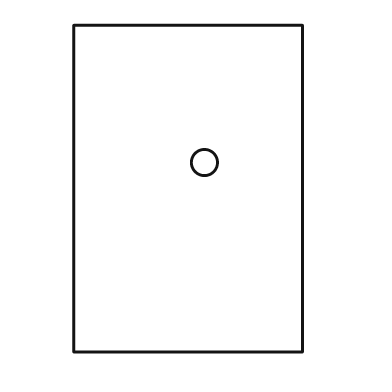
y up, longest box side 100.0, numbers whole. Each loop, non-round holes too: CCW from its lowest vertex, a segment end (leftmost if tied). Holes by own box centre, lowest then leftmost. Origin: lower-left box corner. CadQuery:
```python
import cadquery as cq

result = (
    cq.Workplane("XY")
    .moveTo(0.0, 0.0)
    .lineTo(70.0, 0.0)
    .lineTo(70.0, 100.0)
    .lineTo(0.0, 100.0)
    .close()
    .moveTo(40.0, 58.0)
    .circle(4.0)
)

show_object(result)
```